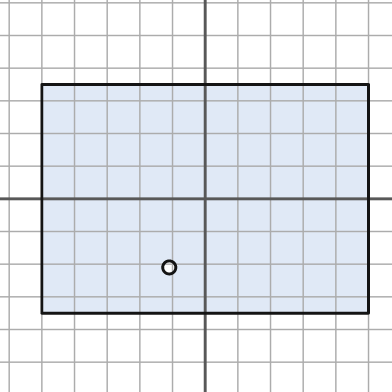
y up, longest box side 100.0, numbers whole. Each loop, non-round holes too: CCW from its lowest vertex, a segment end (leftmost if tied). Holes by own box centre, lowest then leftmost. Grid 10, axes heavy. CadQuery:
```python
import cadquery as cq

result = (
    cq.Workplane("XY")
    .moveTo(-50.0, -35.0)
    .lineTo(50.0, -35.0)
    .lineTo(50.0, 35.0)
    .lineTo(-50.0, 35.0)
    .close()
    .moveTo(-11.0, -21.0)
    .circle(2.0)
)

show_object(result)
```